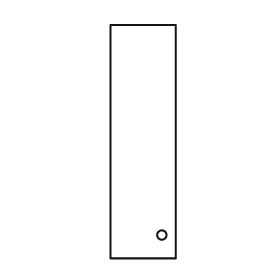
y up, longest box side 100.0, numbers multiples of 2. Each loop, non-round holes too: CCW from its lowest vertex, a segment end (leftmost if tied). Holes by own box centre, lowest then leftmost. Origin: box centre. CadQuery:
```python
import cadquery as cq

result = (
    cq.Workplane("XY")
    .moveTo(-14.0, -50.0)
    .lineTo(14.0, -50.0)
    .lineTo(14.0, 50.0)
    .lineTo(-14.0, 50.0)
    .close()
    .moveTo(8.0, -40.0)
    .circle(2.0)
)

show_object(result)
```